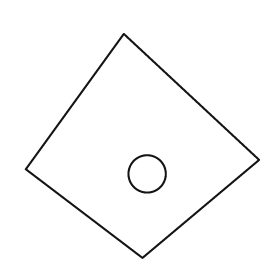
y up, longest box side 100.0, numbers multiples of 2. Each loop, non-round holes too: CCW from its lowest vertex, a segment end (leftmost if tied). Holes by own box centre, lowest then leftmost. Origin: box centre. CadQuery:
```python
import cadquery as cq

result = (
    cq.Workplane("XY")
    .moveTo(0.0, -48.0)
    .lineTo(50.0, -6.0)
    .lineTo(-8.0, 48.0)
    .lineTo(-50.0, -10.0)
    .close()
    .moveTo(2.0, -12.0)
    .circle(8.0)
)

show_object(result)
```